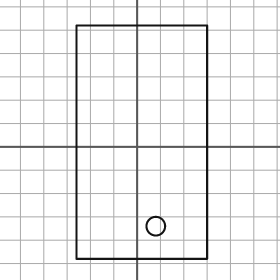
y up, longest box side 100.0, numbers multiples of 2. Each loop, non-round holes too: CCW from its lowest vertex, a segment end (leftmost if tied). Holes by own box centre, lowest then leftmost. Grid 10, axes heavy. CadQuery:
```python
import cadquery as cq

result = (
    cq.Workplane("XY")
    .moveTo(-26.0, -48.0)
    .lineTo(30.0, -48.0)
    .lineTo(30.0, 52.0)
    .lineTo(-26.0, 52.0)
    .close()
    .moveTo(8.0, -34.0)
    .circle(4.0)
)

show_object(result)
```